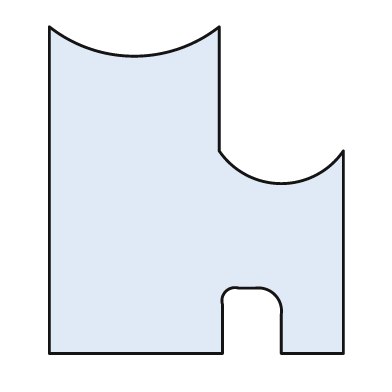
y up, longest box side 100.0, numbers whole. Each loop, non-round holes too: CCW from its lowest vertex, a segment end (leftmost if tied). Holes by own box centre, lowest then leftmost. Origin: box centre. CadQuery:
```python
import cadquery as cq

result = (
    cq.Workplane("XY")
    .moveTo(-45.0, -50.0)
    .lineTo(8.0, -50.0)
    .lineTo(8.0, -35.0)
    .threePointArc((9.0, -31.0), (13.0, -30.0))
    .lineTo(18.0, -30.0)
    .threePointArc((24.0, -32.0), (26.0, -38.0))
    .lineTo(26.0, -50.0)
    .lineTo(45.0, -50.0)
    .lineTo(45.0, 12.0)
    .threePointArc((26.0, 2.0), (7.0, 12.0))
    .lineTo(7.0, 50.0)
    .threePointArc((-19.0, 41.0), (-45.0, 50.0))
    .close()
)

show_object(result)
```